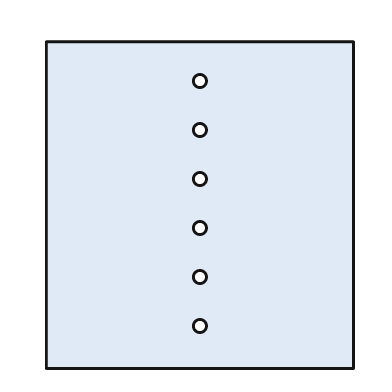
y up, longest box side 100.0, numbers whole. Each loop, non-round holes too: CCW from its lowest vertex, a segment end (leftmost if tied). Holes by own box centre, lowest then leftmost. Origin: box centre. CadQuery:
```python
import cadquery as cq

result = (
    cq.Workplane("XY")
    .moveTo(-47.0, -50.0)
    .lineTo(47.0, -50.0)
    .lineTo(47.0, 50.0)
    .lineTo(-47.0, 50.0)
    .close()
    .moveTo(0.0, -37.0)
    .circle(2.0)
    .moveTo(0.0, -22.0)
    .circle(2.0)
    .moveTo(0.0, -7.0)
    .circle(2.0)
    .moveTo(0.0, 8.0)
    .circle(2.0)
    .moveTo(0.0, 23.0)
    .circle(2.0)
    .moveTo(0.0, 38.0)
    .circle(2.0)
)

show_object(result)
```